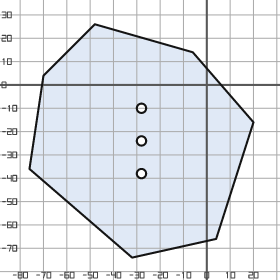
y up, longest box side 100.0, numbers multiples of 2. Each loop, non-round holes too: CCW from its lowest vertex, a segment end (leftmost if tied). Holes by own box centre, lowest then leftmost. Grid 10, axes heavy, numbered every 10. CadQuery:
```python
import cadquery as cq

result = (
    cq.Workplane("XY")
    .moveTo(-32.0, -74.0)
    .lineTo(4.0, -66.0)
    .lineTo(20.0, -16.0)
    .lineTo(-6.0, 14.0)
    .lineTo(-48.0, 26.0)
    .lineTo(-70.0, 4.0)
    .lineTo(-76.0, -36.0)
    .close()
    .moveTo(-28.0, -38.0)
    .circle(2.0)
    .moveTo(-28.0, -24.0)
    .circle(2.0)
    .moveTo(-28.0, -10.0)
    .circle(2.0)
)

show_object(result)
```